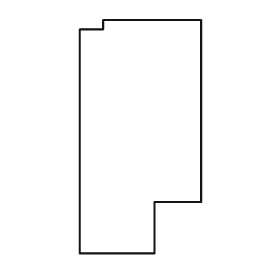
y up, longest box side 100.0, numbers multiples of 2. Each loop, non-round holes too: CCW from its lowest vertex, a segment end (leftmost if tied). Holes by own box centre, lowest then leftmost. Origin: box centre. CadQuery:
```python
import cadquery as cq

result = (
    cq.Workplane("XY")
    .moveTo(-26.0, -50.0)
    .lineTo(6.0, -50.0)
    .lineTo(6.0, -28.0)
    .lineTo(26.0, -28.0)
    .lineTo(26.0, 50.0)
    .lineTo(-16.0, 50.0)
    .lineTo(-16.0, 46.0)
    .lineTo(-26.0, 46.0)
    .close()
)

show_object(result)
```